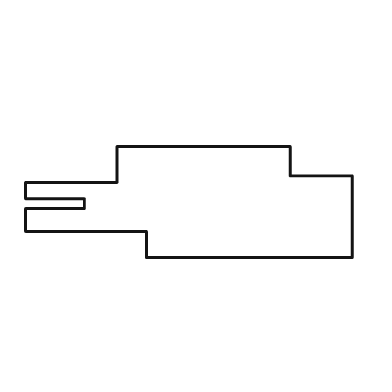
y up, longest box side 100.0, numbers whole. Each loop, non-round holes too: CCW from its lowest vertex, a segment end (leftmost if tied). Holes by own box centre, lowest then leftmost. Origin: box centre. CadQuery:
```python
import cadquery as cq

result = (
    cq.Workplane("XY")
    .moveTo(-13.0, -17.0)
    .lineTo(50.0, -17.0)
    .lineTo(50.0, 8.0)
    .lineTo(31.0, 8.0)
    .lineTo(31.0, 17.0)
    .lineTo(-22.0, 17.0)
    .lineTo(-22.0, 6.0)
    .lineTo(-50.0, 6.0)
    .lineTo(-50.0, 1.0)
    .lineTo(-32.0, 1.0)
    .lineTo(-32.0, -2.0)
    .lineTo(-50.0, -2.0)
    .lineTo(-50.0, -9.0)
    .lineTo(-13.0, -9.0)
    .close()
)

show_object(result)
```